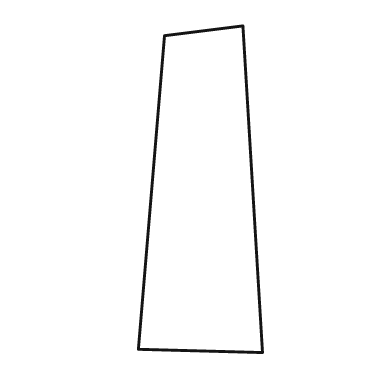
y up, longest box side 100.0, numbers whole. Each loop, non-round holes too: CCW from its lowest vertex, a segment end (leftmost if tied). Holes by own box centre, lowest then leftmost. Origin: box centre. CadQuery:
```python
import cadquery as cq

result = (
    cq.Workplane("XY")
    .moveTo(19.0, -50.0)
    .lineTo(13.0, 50.0)
    .lineTo(-11.0, 47.0)
    .lineTo(-19.0, -49.0)
    .close()
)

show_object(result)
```